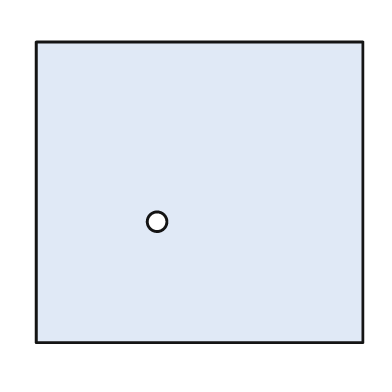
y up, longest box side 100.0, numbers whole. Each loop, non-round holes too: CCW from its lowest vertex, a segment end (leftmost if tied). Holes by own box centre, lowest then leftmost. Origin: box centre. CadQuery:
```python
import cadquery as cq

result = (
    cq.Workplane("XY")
    .moveTo(-50.0, -46.0)
    .lineTo(50.0, -46.0)
    .lineTo(50.0, 46.0)
    .lineTo(-50.0, 46.0)
    .close()
    .moveTo(-13.0, -9.0)
    .circle(3.0)
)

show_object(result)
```